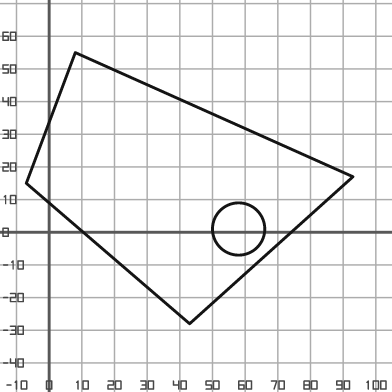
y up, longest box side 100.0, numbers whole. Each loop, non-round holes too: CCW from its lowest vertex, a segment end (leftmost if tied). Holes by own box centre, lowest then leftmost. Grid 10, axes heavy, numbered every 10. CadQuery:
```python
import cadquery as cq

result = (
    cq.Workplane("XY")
    .moveTo(43.0, -28.0)
    .lineTo(93.0, 17.0)
    .lineTo(8.0, 55.0)
    .lineTo(-7.0, 15.0)
    .close()
    .moveTo(58.0, 1.0)
    .circle(8.0)
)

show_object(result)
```